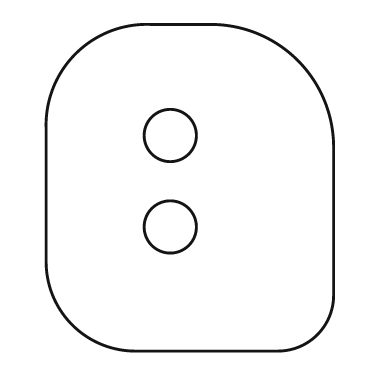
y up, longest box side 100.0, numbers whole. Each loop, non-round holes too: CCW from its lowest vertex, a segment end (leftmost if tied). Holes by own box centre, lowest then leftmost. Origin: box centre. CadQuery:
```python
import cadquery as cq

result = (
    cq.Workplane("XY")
    .moveTo(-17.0, -50.0)
    .lineTo(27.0, -50.0)
    .threePointArc((39.0, -45.0), (44.0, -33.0))
    .lineTo(44.0, 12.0)
    .threePointArc((33.0, 39.0), (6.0, 50.0))
    .lineTo(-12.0, 50.0)
    .threePointArc((-35.0, 41.0), (-44.0, 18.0))
    .lineTo(-44.0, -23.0)
    .threePointArc((-36.0, -42.0), (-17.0, -50.0))
    .close()
    .moveTo(-6.0, -12.0)
    .circle(8.0)
    .moveTo(-6.0, 16.0)
    .circle(8.0)
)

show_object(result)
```